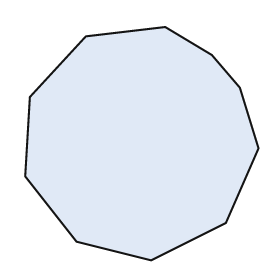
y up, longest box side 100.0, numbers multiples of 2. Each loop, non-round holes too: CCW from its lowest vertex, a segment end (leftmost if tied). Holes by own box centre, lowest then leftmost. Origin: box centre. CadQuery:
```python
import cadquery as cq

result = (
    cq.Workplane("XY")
    .moveTo(4.0, -50.0)
    .lineTo(36.0, -34.0)
    .lineTo(50.0, -2.0)
    .lineTo(42.0, 24.0)
    .lineTo(30.0, 38.0)
    .lineTo(10.0, 50.0)
    .lineTo(-24.0, 46.0)
    .lineTo(-48.0, 20.0)
    .lineTo(-50.0, -14.0)
    .lineTo(-28.0, -42.0)
    .close()
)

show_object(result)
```